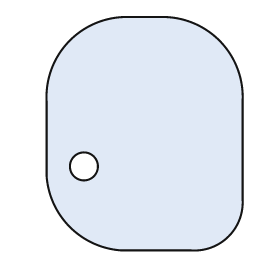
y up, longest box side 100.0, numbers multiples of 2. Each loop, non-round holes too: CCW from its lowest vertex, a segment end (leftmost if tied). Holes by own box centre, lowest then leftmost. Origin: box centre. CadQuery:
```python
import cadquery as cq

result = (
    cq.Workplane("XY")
    .moveTo(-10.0, -50.0)
    .lineTo(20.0, -50.0)
    .threePointArc((36.0, -44.0), (42.0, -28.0))
    .lineTo(42.0, 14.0)
    .threePointArc((32.0, 40.0), (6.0, 50.0))
    .lineTo(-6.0, 50.0)
    .threePointArc((-32.0, 40.0), (-42.0, 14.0))
    .lineTo(-42.0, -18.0)
    .threePointArc((-32.0, -40.0), (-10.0, -50.0))
    .close()
    .moveTo(-26.0, -14.0)
    .circle(6.0)
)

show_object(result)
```